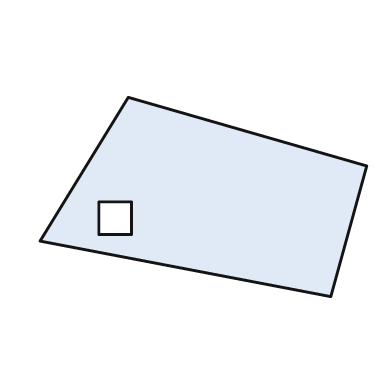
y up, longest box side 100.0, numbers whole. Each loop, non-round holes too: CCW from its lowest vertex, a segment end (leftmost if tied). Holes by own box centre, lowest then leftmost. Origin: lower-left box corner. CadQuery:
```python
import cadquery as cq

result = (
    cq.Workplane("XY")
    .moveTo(89.0, 0.0)
    .lineTo(100.0, 40.0)
    .lineTo(27.0, 61.0)
    .lineTo(0.0, 17.0)
    .close()
    .moveTo(18.0, 19.0)
    .lineTo(28.0, 19.0)
    .lineTo(28.0, 29.0)
    .lineTo(18.0, 29.0)
    .close()
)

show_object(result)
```